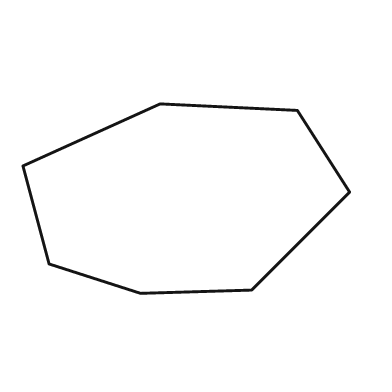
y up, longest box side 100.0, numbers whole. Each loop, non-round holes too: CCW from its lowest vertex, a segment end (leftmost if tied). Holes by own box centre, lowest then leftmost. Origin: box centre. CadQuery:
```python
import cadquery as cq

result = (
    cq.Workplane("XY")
    .moveTo(-14.0, -29.0)
    .lineTo(20.0, -28.0)
    .lineTo(50.0, 2.0)
    .lineTo(34.0, 27.0)
    .lineTo(-8.0, 29.0)
    .lineTo(-50.0, 10.0)
    .lineTo(-42.0, -20.0)
    .close()
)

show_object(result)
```